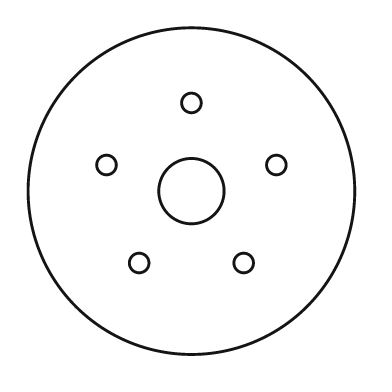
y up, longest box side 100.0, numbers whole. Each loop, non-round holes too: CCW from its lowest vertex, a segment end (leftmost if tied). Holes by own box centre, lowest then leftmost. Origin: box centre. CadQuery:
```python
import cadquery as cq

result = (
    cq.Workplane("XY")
    .moveTo(0.0, 0.0)
    .circle(50.0)
    .moveTo(-16.0, -22.0)
    .circle(3.0)
    .moveTo(16.0, -22.0)
    .circle(3.0)
    .moveTo(0.0, 0.0)
    .circle(10.0)
    .moveTo(-26.0, 8.0)
    .circle(3.0)
    .moveTo(26.0, 8.0)
    .circle(3.0)
    .moveTo(0.0, 27.0)
    .circle(3.0)
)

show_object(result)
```